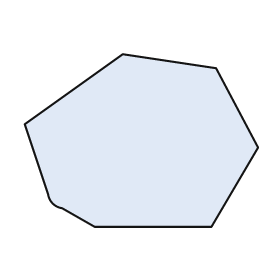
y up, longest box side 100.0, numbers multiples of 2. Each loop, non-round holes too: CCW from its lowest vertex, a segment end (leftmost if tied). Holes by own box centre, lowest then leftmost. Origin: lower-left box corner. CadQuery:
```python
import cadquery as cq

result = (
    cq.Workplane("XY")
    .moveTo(30.0, 0.0)
    .lineTo(80.0, 0.0)
    .lineTo(100.0, 34.0)
    .lineTo(82.0, 68.0)
    .lineTo(42.0, 74.0)
    .lineTo(0.0, 44.0)
    .lineTo(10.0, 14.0)
    .threePointArc((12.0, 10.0), (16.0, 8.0))
    .close()
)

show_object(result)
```